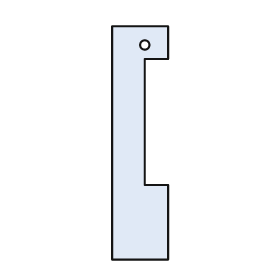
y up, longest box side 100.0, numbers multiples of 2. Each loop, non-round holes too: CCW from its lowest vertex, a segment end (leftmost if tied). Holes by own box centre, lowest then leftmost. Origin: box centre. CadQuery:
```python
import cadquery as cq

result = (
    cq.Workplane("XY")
    .moveTo(-12.0, -50.0)
    .lineTo(12.0, -50.0)
    .lineTo(12.0, -18.0)
    .lineTo(2.0, -18.0)
    .lineTo(2.0, 36.0)
    .lineTo(12.0, 36.0)
    .lineTo(12.0, 50.0)
    .lineTo(-12.0, 50.0)
    .close()
    .moveTo(2.0, 42.0)
    .circle(2.0)
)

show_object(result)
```